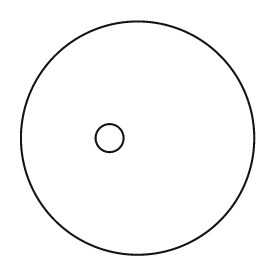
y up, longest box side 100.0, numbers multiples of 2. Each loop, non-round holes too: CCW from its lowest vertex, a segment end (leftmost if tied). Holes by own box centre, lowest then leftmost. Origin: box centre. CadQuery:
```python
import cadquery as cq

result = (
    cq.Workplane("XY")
    .moveTo(0.0, 0.0)
    .circle(50.0)
    .moveTo(-12.0, 0.0)
    .circle(6.0)
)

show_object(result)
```